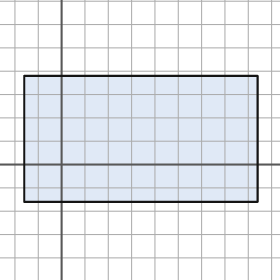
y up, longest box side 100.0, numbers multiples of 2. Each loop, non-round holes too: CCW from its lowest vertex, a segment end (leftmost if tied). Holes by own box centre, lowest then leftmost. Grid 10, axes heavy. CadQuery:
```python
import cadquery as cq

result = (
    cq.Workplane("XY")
    .moveTo(-16.0, -16.0)
    .lineTo(84.0, -16.0)
    .lineTo(84.0, 38.0)
    .lineTo(-16.0, 38.0)
    .close()
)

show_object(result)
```